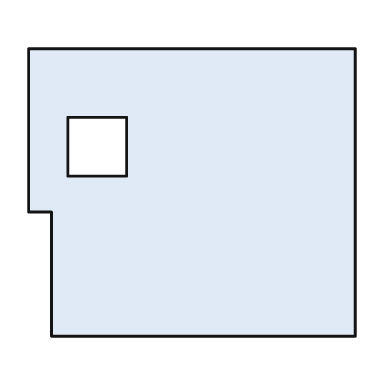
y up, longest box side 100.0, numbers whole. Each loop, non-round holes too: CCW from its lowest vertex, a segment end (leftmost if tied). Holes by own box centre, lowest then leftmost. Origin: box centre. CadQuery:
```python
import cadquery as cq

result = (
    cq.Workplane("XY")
    .moveTo(-43.0, -44.0)
    .lineTo(50.0, -44.0)
    .lineTo(50.0, 44.0)
    .lineTo(-50.0, 44.0)
    .lineTo(-50.0, -6.0)
    .lineTo(-43.0, -6.0)
    .close()
    .moveTo(-38.0, 5.0)
    .lineTo(-20.0, 5.0)
    .lineTo(-20.0, 23.0)
    .lineTo(-38.0, 23.0)
    .close()
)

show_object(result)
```